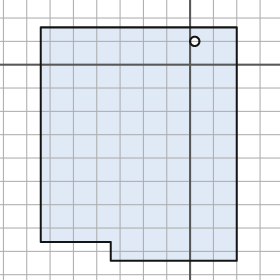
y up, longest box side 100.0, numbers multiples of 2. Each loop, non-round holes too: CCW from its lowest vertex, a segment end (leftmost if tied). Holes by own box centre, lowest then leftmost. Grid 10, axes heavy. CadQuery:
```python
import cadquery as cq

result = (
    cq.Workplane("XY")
    .moveTo(-34.0, -84.0)
    .lineTo(20.0, -84.0)
    .lineTo(20.0, 16.0)
    .lineTo(-64.0, 16.0)
    .lineTo(-64.0, -76.0)
    .lineTo(-34.0, -76.0)
    .close()
    .moveTo(2.0, 10.0)
    .circle(2.0)
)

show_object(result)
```